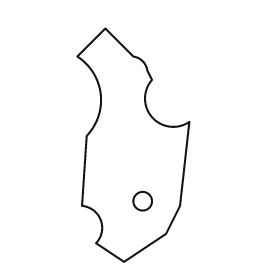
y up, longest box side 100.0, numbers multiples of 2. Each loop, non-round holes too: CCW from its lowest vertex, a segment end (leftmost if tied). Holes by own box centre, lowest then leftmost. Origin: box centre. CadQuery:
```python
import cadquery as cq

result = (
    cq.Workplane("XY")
    .moveTo(-4.0, -50.0)
    .lineTo(14.0, -38.0)
    .lineTo(20.0, -26.0)
    .lineTo(24.0, 10.0)
    .threePointArc((8.0, 12.0), (8.0, 28.0))
    .lineTo(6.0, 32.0)
    .threePointArc((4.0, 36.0), (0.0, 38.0))
    .lineTo(-12.0, 50.0)
    .lineTo(-24.0, 38.0)
    .threePointArc((-14.0, 22.0), (-20.0, 4.0))
    .lineTo(-22.0, -26.0)
    .threePointArc((-14.0, -32.0), (-16.0, -42.0))
    .close()
    .moveTo(4.0, -24.0)
    .circle(4.0)
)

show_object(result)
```